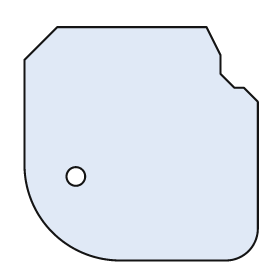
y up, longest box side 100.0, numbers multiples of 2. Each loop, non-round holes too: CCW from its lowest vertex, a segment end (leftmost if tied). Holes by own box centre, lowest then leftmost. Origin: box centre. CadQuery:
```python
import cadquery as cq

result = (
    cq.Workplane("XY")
    .moveTo(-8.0, -50.0)
    .lineTo(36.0, -50.0)
    .threePointArc((46.0, -46.0), (50.0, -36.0))
    .lineTo(50.0, 18.0)
    .lineTo(44.0, 24.0)
    .lineTo(40.0, 24.0)
    .lineTo(34.0, 30.0)
    .lineTo(34.0, 38.0)
    .lineTo(28.0, 50.0)
    .lineTo(-36.0, 50.0)
    .lineTo(-50.0, 36.0)
    .lineTo(-50.0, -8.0)
    .threePointArc((-38.0, -38.0), (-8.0, -50.0))
    .close()
    .moveTo(-28.0, -14.0)
    .circle(4.0)
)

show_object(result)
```